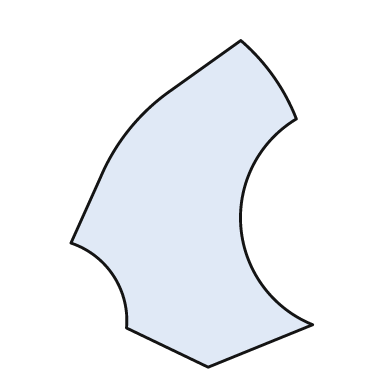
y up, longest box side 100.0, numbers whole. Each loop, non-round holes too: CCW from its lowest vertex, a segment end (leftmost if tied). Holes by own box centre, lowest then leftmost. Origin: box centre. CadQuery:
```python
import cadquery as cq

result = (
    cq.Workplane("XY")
    .moveTo(5.0, -50.0)
    .lineTo(37.0, -37.0)
    .threePointArc((15.0, -7.0), (32.0, 26.0))
    .threePointArc((25.0, 39.0), (15.0, 50.0))
    .lineTo(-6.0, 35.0)
    .threePointArc((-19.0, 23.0), (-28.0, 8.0))
    .lineTo(-37.0, -12.0)
    .threePointArc((-24.0, -22.0), (-20.0, -38.0))
    .close()
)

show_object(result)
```